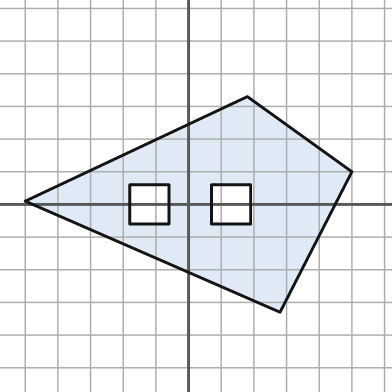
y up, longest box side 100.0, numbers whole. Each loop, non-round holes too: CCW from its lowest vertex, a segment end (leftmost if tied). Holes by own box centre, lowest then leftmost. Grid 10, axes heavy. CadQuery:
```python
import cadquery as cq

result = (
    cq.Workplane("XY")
    .moveTo(28.0, -33.0)
    .lineTo(50.0, 10.0)
    .lineTo(18.0, 33.0)
    .lineTo(-50.0, 1.0)
    .close()
    .moveTo(-18.0, -6.0)
    .lineTo(-6.0, -6.0)
    .lineTo(-6.0, 6.0)
    .lineTo(-18.0, 6.0)
    .close()
    .moveTo(7.0, -6.0)
    .lineTo(19.0, -6.0)
    .lineTo(19.0, 6.0)
    .lineTo(7.0, 6.0)
    .close()
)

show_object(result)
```